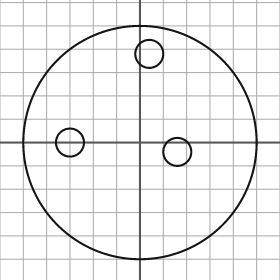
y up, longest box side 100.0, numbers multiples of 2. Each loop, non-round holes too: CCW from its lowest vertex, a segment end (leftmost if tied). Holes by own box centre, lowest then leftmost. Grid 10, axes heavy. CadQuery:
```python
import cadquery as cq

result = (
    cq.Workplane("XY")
    .moveTo(0.0, 0.0)
    .circle(50.0)
    .moveTo(16.0, -4.0)
    .circle(6.0)
    .moveTo(-30.0, 0.0)
    .circle(6.0)
    .moveTo(4.0, 38.0)
    .circle(6.0)
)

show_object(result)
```